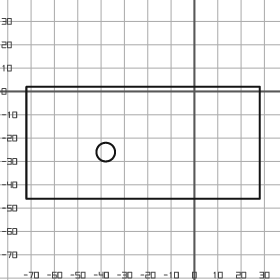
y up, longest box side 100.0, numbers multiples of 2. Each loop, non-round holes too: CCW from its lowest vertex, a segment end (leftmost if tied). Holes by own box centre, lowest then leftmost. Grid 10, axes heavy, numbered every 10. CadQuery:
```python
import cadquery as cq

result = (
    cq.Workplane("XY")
    .moveTo(-72.0, -46.0)
    .lineTo(28.0, -46.0)
    .lineTo(28.0, 2.0)
    .lineTo(-72.0, 2.0)
    .close()
    .moveTo(-38.0, -26.0)
    .circle(4.0)
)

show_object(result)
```